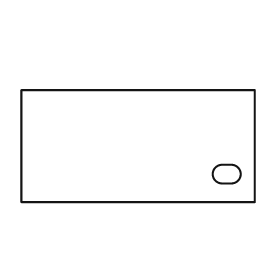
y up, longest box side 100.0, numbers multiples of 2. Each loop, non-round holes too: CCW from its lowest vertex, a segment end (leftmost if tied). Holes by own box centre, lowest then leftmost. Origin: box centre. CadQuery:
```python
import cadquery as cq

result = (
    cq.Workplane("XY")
    .moveTo(-50.0, -24.0)
    .lineTo(50.0, -24.0)
    .lineTo(50.0, 24.0)
    .lineTo(-50.0, 24.0)
    .close()
    .moveTo(36.0, -16.0)
    .lineTo(40.0, -16.0)
    .threePointArc((44.0, -12.0), (40.0, -8.0))
    .lineTo(36.0, -8.0)
    .threePointArc((32.0, -12.0), (36.0, -16.0))
    .close()
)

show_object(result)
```